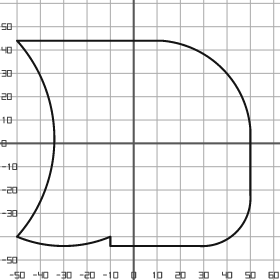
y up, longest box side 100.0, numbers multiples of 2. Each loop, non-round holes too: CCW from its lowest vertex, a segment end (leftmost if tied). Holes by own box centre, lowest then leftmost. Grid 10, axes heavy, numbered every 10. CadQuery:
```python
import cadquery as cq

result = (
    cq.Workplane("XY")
    .moveTo(-10.0, -44.0)
    .lineTo(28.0, -44.0)
    .threePointArc((44.0, -38.0), (50.0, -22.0))
    .lineTo(50.0, 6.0)
    .threePointArc((38.0, 32.0), (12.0, 44.0))
    .lineTo(-50.0, 44.0)
    .threePointArc((-34.0, 2.0), (-50.0, -40.0))
    .threePointArc((-30.0, -44.0), (-10.0, -40.0))
    .close()
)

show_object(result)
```